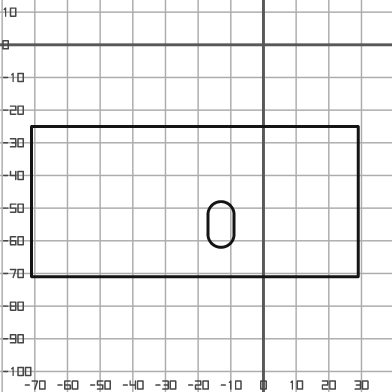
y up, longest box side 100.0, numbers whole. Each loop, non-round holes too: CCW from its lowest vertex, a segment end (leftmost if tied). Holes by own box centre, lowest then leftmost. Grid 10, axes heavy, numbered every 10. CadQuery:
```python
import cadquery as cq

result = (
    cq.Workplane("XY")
    .moveTo(-71.0, -71.0)
    .lineTo(29.0, -71.0)
    .lineTo(29.0, -25.0)
    .lineTo(-71.0, -25.0)
    .close()
    .moveTo(-17.0, -58.0)
    .threePointArc((-13.0, -62.0), (-9.0, -58.0))
    .lineTo(-9.0, -52.0)
    .threePointArc((-13.0, -48.0), (-17.0, -52.0))
    .close()
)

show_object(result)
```